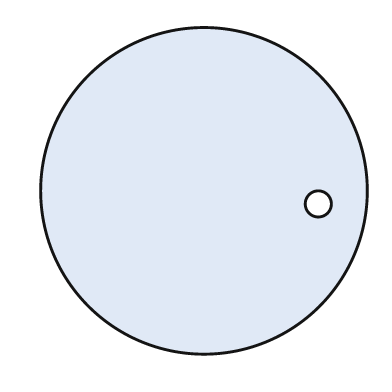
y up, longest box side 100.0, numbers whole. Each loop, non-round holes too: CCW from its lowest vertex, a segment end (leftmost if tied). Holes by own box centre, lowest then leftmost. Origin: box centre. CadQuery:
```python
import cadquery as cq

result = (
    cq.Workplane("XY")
    .moveTo(0.0, 0.0)
    .circle(50.0)
    .moveTo(35.0, -4.0)
    .circle(4.0)
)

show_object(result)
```